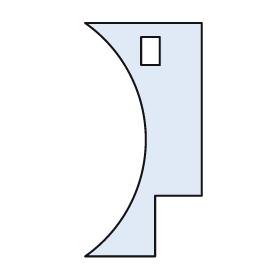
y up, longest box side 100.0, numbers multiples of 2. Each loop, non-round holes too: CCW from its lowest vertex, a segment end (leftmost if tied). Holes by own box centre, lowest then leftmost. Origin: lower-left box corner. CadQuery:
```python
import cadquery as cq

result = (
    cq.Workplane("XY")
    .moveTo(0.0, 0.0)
    .lineTo(30.0, 0.0)
    .lineTo(30.0, 26.0)
    .lineTo(50.0, 26.0)
    .lineTo(50.0, 100.0)
    .lineTo(0.0, 100.0)
    .threePointArc((26.0, 50.0), (0.0, 0.0))
    .close()
    .moveTo(24.0, 82.0)
    .lineTo(32.0, 82.0)
    .lineTo(32.0, 94.0)
    .lineTo(24.0, 94.0)
    .close()
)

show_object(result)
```